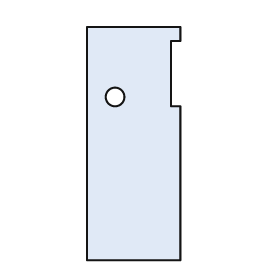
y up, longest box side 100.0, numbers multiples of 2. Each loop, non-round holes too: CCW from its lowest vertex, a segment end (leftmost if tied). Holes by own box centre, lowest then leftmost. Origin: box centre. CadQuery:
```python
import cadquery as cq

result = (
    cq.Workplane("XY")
    .moveTo(-20.0, -50.0)
    .lineTo(20.0, -50.0)
    .lineTo(20.0, 16.0)
    .lineTo(16.0, 16.0)
    .lineTo(16.0, 44.0)
    .lineTo(20.0, 44.0)
    .lineTo(20.0, 50.0)
    .lineTo(-20.0, 50.0)
    .close()
    .moveTo(-8.0, 20.0)
    .circle(4.0)
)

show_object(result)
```